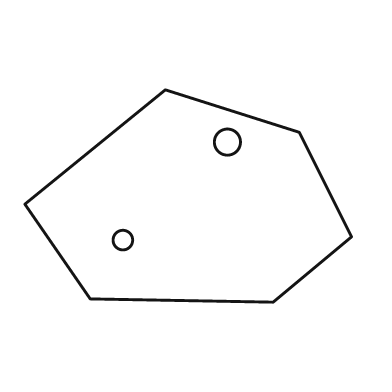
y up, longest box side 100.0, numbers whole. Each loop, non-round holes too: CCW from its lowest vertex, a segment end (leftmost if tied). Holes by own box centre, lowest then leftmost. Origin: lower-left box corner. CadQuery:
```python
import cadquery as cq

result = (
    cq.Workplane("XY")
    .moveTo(76.0, 0.0)
    .lineTo(100.0, 20.0)
    .lineTo(84.0, 52.0)
    .lineTo(43.0, 65.0)
    .lineTo(0.0, 30.0)
    .lineTo(20.0, 1.0)
    .close()
    .moveTo(30.0, 19.0)
    .circle(3.0)
    .moveTo(62.0, 49.0)
    .circle(4.0)
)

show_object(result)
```